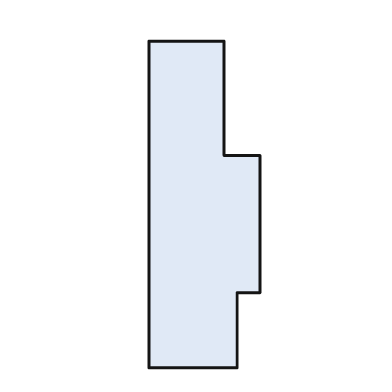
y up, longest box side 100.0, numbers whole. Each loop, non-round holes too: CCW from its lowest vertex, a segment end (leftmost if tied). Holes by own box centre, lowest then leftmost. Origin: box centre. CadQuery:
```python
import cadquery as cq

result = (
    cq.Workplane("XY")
    .moveTo(-17.0, -50.0)
    .lineTo(10.0, -50.0)
    .lineTo(10.0, -27.0)
    .lineTo(17.0, -27.0)
    .lineTo(17.0, 15.0)
    .lineTo(6.0, 15.0)
    .lineTo(6.0, 50.0)
    .lineTo(-17.0, 50.0)
    .close()
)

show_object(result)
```